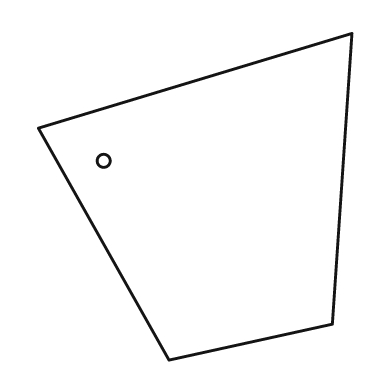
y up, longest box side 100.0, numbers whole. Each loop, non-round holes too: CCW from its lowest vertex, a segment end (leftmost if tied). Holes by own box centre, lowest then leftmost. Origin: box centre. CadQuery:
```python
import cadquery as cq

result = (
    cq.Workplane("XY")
    .moveTo(-8.0, -50.0)
    .lineTo(42.0, -39.0)
    .lineTo(48.0, 50.0)
    .lineTo(-48.0, 21.0)
    .close()
    .moveTo(-28.0, 11.0)
    .circle(2.0)
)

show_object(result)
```